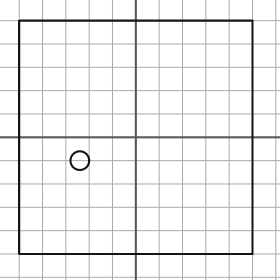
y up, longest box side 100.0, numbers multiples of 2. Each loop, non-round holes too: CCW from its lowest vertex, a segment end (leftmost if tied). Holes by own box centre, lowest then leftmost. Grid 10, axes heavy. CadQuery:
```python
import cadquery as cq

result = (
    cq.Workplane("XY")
    .moveTo(-50.0, -50.0)
    .lineTo(50.0, -50.0)
    .lineTo(50.0, 50.0)
    .lineTo(-50.0, 50.0)
    .close()
    .moveTo(-24.0, -10.0)
    .circle(4.0)
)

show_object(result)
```